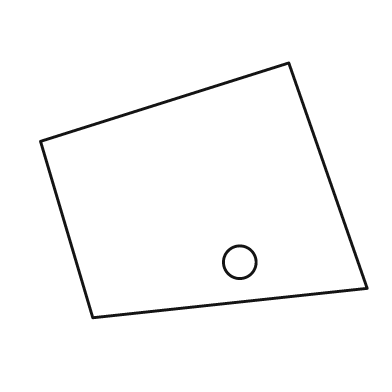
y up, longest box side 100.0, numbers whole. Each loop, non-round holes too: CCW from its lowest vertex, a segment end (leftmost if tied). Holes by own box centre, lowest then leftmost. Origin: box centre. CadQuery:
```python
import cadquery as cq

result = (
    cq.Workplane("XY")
    .moveTo(-34.0, -39.0)
    .lineTo(50.0, -30.0)
    .lineTo(26.0, 39.0)
    .lineTo(-50.0, 15.0)
    .close()
    .moveTo(11.0, -22.0)
    .circle(5.0)
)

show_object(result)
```